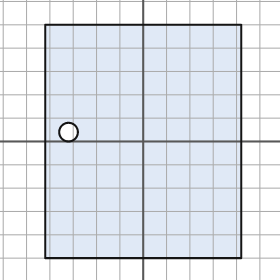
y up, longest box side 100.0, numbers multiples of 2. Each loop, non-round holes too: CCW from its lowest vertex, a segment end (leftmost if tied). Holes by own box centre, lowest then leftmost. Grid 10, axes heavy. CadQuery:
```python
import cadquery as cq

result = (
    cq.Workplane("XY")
    .moveTo(-42.0, -50.0)
    .lineTo(42.0, -50.0)
    .lineTo(42.0, 50.0)
    .lineTo(-42.0, 50.0)
    .close()
    .moveTo(-32.0, 4.0)
    .circle(4.0)
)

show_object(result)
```